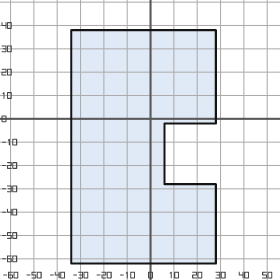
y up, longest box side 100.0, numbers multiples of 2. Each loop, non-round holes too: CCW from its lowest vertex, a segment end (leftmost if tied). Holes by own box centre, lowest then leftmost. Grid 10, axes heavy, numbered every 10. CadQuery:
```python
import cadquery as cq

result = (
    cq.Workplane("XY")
    .moveTo(-34.0, -62.0)
    .lineTo(28.0, -62.0)
    .lineTo(28.0, -28.0)
    .lineTo(6.0, -28.0)
    .lineTo(6.0, -2.0)
    .lineTo(28.0, -2.0)
    .lineTo(28.0, 38.0)
    .lineTo(-34.0, 38.0)
    .close()
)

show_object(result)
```